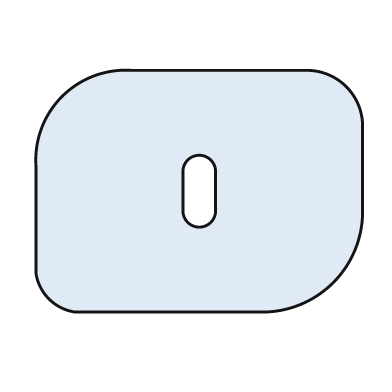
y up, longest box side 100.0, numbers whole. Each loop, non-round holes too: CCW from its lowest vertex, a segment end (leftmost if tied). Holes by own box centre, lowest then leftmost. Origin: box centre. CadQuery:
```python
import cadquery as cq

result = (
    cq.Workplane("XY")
    .moveTo(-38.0, -37.0)
    .lineTo(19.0, -37.0)
    .threePointArc((41.0, -28.0), (50.0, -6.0))
    .lineTo(50.0, 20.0)
    .threePointArc((45.0, 32.0), (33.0, 37.0))
    .lineTo(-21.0, 37.0)
    .threePointArc((-42.0, 29.0), (-50.0, 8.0))
    .lineTo(-50.0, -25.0)
    .threePointArc((-46.0, -33.0), (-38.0, -37.0))
    .close()
    .moveTo(-5.0, -6.0)
    .threePointArc((0.0, -11.0), (5.0, -6.0))
    .lineTo(5.0, 6.0)
    .threePointArc((0.0, 11.0), (-5.0, 6.0))
    .close()
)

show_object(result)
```